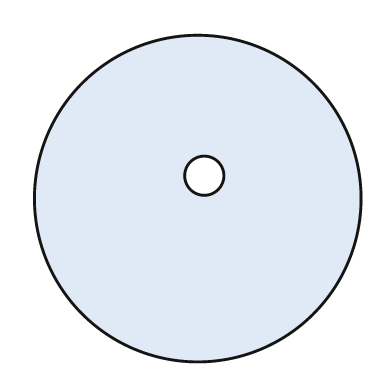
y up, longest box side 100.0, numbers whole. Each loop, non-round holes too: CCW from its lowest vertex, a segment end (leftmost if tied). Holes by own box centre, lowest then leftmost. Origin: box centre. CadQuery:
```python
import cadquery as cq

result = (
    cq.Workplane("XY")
    .moveTo(0.0, 0.0)
    .circle(50.0)
    .moveTo(2.0, 7.0)
    .circle(6.0)
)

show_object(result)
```